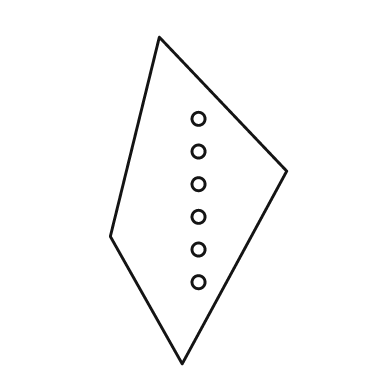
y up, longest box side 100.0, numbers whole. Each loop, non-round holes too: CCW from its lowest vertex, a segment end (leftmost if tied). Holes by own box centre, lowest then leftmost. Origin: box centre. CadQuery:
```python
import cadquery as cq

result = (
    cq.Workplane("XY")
    .moveTo(-5.0, -50.0)
    .lineTo(27.0, 9.0)
    .lineTo(-12.0, 50.0)
    .lineTo(-27.0, -11.0)
    .close()
    .moveTo(0.0, -25.0)
    .circle(2.0)
    .moveTo(0.0, -15.0)
    .circle(2.0)
    .moveTo(0.0, -5.0)
    .circle(2.0)
    .moveTo(0.0, 5.0)
    .circle(2.0)
    .moveTo(0.0, 15.0)
    .circle(2.0)
    .moveTo(0.0, 25.0)
    .circle(2.0)
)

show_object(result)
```